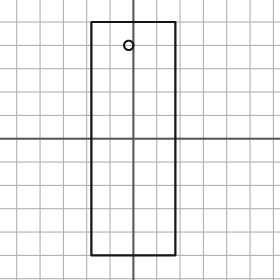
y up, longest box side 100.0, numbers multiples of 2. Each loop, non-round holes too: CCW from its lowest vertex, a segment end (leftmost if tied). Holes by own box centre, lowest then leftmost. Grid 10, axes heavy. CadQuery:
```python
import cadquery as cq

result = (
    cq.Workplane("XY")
    .moveTo(-18.0, -50.0)
    .lineTo(18.0, -50.0)
    .lineTo(18.0, 50.0)
    .lineTo(-18.0, 50.0)
    .close()
    .moveTo(-2.0, 40.0)
    .circle(2.0)
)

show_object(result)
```